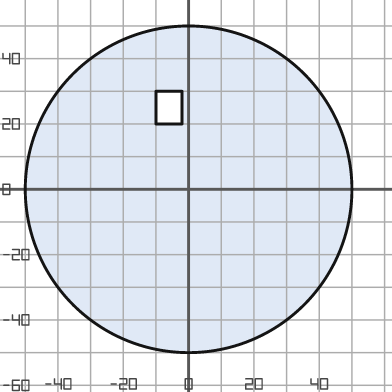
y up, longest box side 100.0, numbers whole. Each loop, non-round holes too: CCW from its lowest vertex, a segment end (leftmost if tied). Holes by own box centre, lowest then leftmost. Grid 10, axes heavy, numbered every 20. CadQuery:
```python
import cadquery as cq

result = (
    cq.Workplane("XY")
    .moveTo(0.0, 0.0)
    .circle(50.0)
    .moveTo(-10.0, 20.0)
    .lineTo(-2.0, 20.0)
    .lineTo(-2.0, 30.0)
    .lineTo(-10.0, 30.0)
    .close()
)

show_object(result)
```